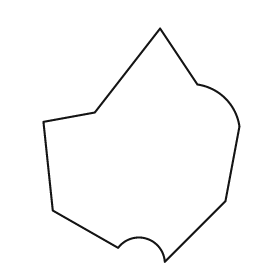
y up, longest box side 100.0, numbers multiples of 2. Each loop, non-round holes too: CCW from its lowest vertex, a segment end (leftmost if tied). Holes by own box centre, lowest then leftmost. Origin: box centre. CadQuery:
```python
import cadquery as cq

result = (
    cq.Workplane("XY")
    .moveTo(10.0, -50.0)
    .lineTo(36.0, -24.0)
    .lineTo(42.0, 8.0)
    .threePointArc((36.0, 20.0), (24.0, 26.0))
    .lineTo(8.0, 50.0)
    .lineTo(-20.0, 14.0)
    .lineTo(-42.0, 10.0)
    .lineTo(-38.0, -28.0)
    .lineTo(-10.0, -44.0)
    .threePointArc((2.0, -40.0), (10.0, -50.0))
    .close()
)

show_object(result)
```